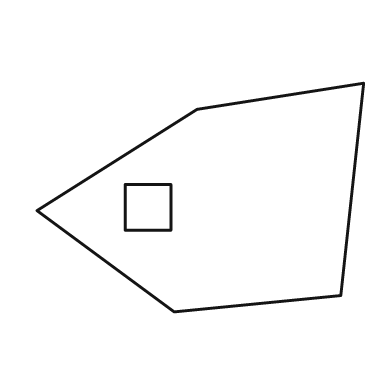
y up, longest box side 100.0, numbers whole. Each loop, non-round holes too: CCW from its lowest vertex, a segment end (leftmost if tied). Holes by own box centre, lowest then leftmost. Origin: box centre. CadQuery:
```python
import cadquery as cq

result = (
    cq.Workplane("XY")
    .moveTo(-8.0, -35.0)
    .lineTo(43.0, -30.0)
    .lineTo(50.0, 35.0)
    .lineTo(-1.0, 27.0)
    .lineTo(-50.0, -4.0)
    .close()
    .moveTo(-23.0, -10.0)
    .lineTo(-9.0, -10.0)
    .lineTo(-9.0, 4.0)
    .lineTo(-23.0, 4.0)
    .close()
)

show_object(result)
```